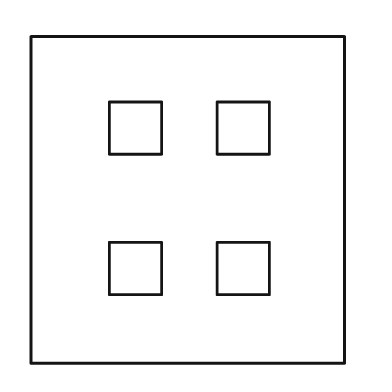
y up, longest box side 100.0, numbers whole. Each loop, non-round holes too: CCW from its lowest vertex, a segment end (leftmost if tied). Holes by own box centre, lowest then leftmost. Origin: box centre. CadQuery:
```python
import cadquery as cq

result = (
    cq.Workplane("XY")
    .moveTo(-48.0, -50.0)
    .lineTo(48.0, -50.0)
    .lineTo(48.0, 50.0)
    .lineTo(-48.0, 50.0)
    .close()
    .moveTo(-24.0, -29.0)
    .lineTo(-8.0, -29.0)
    .lineTo(-8.0, -13.0)
    .lineTo(-24.0, -13.0)
    .close()
    .moveTo(9.0, -29.0)
    .lineTo(25.0, -29.0)
    .lineTo(25.0, -13.0)
    .lineTo(9.0, -13.0)
    .close()
    .moveTo(-24.0, 14.0)
    .lineTo(-8.0, 14.0)
    .lineTo(-8.0, 30.0)
    .lineTo(-24.0, 30.0)
    .close()
    .moveTo(9.0, 14.0)
    .lineTo(25.0, 14.0)
    .lineTo(25.0, 30.0)
    .lineTo(9.0, 30.0)
    .close()
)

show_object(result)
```